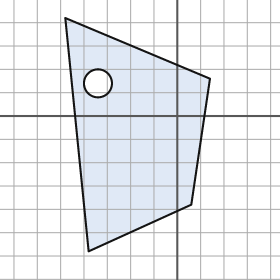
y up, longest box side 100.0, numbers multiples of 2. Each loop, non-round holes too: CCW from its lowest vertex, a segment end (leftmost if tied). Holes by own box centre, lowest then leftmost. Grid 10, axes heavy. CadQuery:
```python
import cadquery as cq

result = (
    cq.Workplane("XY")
    .moveTo(-38.0, -58.0)
    .lineTo(6.0, -38.0)
    .lineTo(14.0, 16.0)
    .lineTo(-48.0, 42.0)
    .close()
    .moveTo(-34.0, 14.0)
    .circle(6.0)
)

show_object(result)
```